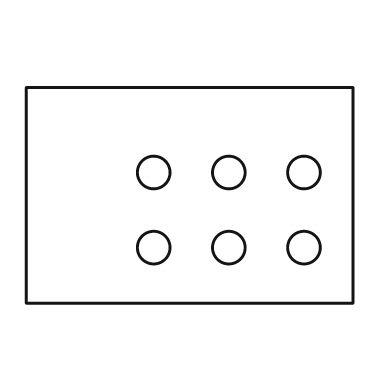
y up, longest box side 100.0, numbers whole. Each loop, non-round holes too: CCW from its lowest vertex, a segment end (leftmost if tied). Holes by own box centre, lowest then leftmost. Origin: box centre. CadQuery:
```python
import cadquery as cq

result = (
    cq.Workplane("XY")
    .moveTo(-50.0, -33.0)
    .lineTo(50.0, -33.0)
    .lineTo(50.0, 33.0)
    .lineTo(-50.0, 33.0)
    .close()
    .moveTo(-11.0, -16.0)
    .circle(5.0)
    .moveTo(12.0, -16.0)
    .circle(5.0)
    .moveTo(35.0, -16.0)
    .circle(5.0)
    .moveTo(-11.0, 7.0)
    .circle(5.0)
    .moveTo(12.0, 7.0)
    .circle(5.0)
    .moveTo(35.0, 7.0)
    .circle(5.0)
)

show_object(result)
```